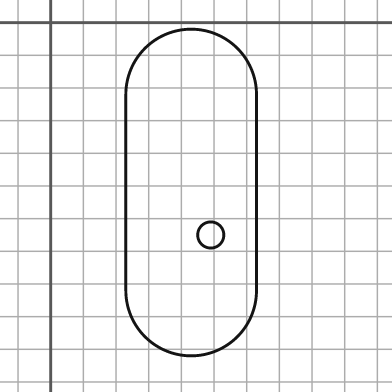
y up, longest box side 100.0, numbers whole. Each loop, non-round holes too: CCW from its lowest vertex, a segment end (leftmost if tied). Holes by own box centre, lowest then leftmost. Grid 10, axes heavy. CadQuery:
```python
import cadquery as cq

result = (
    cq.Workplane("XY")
    .moveTo(23.0, -82.0)
    .threePointArc((43.0, -102.0), (63.0, -82.0))
    .lineTo(63.0, -22.0)
    .threePointArc((43.0, -2.0), (23.0, -22.0))
    .close()
    .moveTo(49.0, -65.0)
    .circle(4.0)
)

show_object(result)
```